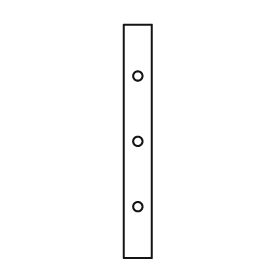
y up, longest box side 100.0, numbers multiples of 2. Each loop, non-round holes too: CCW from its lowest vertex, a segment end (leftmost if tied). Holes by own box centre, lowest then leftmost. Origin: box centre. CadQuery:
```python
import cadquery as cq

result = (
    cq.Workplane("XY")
    .moveTo(-6.0, -50.0)
    .lineTo(6.0, -50.0)
    .lineTo(6.0, 50.0)
    .lineTo(-6.0, 50.0)
    .close()
    .moveTo(0.0, -28.0)
    .circle(2.0)
    .moveTo(0.0, 0.0)
    .circle(2.0)
    .moveTo(0.0, 28.0)
    .circle(2.0)
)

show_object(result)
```